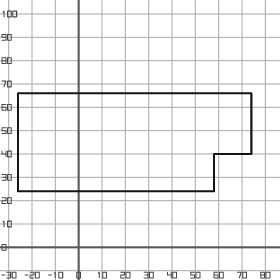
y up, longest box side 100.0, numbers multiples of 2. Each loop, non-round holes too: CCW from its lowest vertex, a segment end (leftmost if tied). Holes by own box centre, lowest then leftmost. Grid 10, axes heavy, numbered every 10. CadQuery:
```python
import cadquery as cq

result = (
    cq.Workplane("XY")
    .moveTo(-26.0, 24.0)
    .lineTo(58.0, 24.0)
    .lineTo(58.0, 40.0)
    .lineTo(74.0, 40.0)
    .lineTo(74.0, 66.0)
    .lineTo(-26.0, 66.0)
    .close()
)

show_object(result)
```